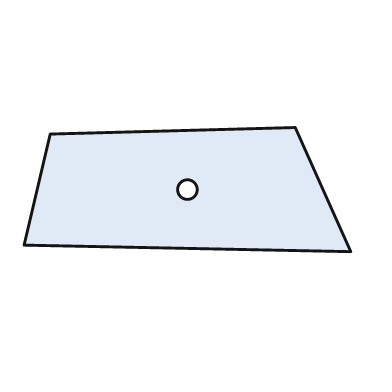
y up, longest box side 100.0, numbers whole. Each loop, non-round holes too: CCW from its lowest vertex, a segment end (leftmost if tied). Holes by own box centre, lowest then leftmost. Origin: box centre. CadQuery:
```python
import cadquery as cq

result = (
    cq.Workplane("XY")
    .moveTo(50.0, -19.0)
    .lineTo(33.0, 19.0)
    .lineTo(-42.0, 17.0)
    .lineTo(-50.0, -17.0)
    .close()
    .moveTo(0.0, 0.0)
    .circle(3.0)
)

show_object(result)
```